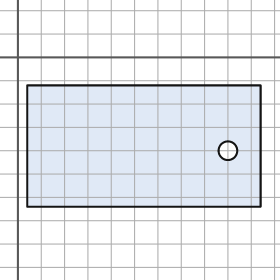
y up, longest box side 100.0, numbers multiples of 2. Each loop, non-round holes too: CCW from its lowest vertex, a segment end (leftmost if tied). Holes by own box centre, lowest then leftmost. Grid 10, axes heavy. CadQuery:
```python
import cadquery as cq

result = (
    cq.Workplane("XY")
    .moveTo(4.0, -64.0)
    .lineTo(104.0, -64.0)
    .lineTo(104.0, -12.0)
    .lineTo(4.0, -12.0)
    .close()
    .moveTo(90.0, -40.0)
    .circle(4.0)
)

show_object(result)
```